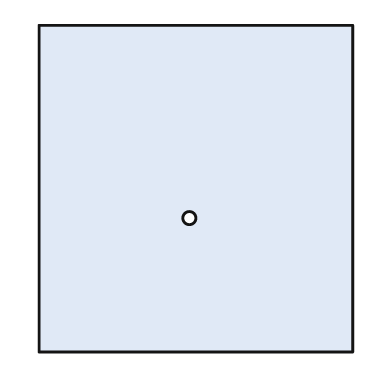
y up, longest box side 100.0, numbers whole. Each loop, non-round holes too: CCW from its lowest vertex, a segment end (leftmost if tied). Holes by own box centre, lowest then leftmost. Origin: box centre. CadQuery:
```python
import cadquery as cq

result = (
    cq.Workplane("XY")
    .moveTo(-48.0, -50.0)
    .lineTo(48.0, -50.0)
    .lineTo(48.0, 50.0)
    .lineTo(-48.0, 50.0)
    .close()
    .moveTo(-2.0, -9.0)
    .circle(2.0)
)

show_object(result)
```